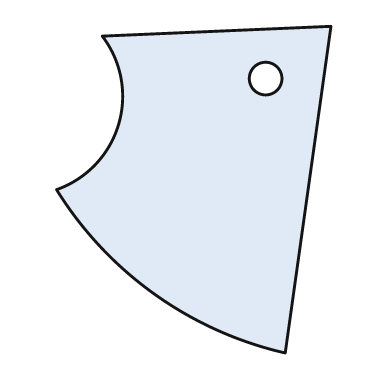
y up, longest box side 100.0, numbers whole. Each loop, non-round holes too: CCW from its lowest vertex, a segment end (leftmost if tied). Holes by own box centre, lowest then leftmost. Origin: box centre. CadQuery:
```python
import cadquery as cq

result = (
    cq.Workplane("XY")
    .moveTo(28.0, -50.0)
    .lineTo(42.0, 50.0)
    .lineTo(-28.0, 47.0)
    .threePointArc((-23.0, 20.0), (-42.0, 0.0))
    .threePointArc((-12.0, -32.0), (28.0, -50.0))
    .close()
    .moveTo(22.0, 34.0)
    .circle(5.0)
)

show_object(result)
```